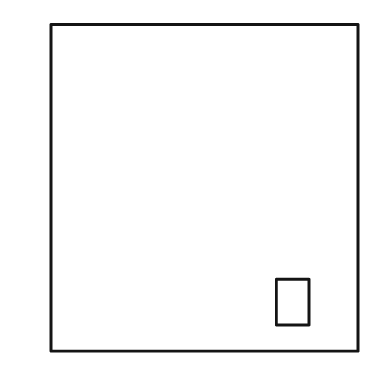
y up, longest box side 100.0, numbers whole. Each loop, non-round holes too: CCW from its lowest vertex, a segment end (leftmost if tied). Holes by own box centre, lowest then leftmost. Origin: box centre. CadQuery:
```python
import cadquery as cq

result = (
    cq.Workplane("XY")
    .moveTo(-47.0, -50.0)
    .lineTo(47.0, -50.0)
    .lineTo(47.0, 50.0)
    .lineTo(-47.0, 50.0)
    .close()
    .moveTo(22.0, -42.0)
    .lineTo(32.0, -42.0)
    .lineTo(32.0, -28.0)
    .lineTo(22.0, -28.0)
    .close()
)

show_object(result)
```